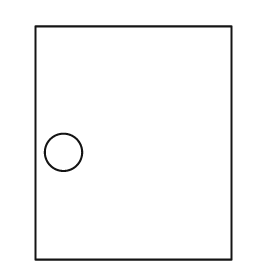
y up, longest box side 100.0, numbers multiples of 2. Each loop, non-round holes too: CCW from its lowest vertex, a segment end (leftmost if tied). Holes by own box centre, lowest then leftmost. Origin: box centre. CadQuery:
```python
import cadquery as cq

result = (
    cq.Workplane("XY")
    .moveTo(-42.0, -50.0)
    .lineTo(42.0, -50.0)
    .lineTo(42.0, 50.0)
    .lineTo(-42.0, 50.0)
    .close()
    .moveTo(-30.0, -4.0)
    .circle(8.0)
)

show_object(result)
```